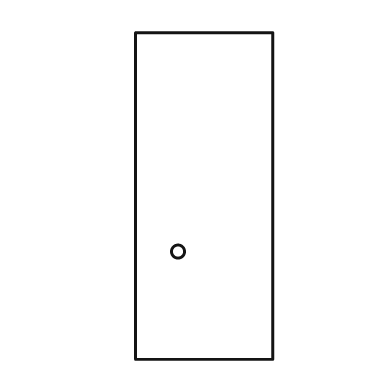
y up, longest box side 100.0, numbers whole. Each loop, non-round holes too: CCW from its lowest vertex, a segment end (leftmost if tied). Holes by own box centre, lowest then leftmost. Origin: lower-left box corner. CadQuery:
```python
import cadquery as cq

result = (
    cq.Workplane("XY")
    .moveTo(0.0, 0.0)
    .lineTo(42.0, 0.0)
    .lineTo(42.0, 100.0)
    .lineTo(0.0, 100.0)
    .close()
    .moveTo(13.0, 33.0)
    .circle(2.0)
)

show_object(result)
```